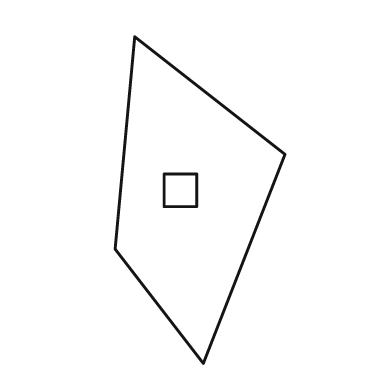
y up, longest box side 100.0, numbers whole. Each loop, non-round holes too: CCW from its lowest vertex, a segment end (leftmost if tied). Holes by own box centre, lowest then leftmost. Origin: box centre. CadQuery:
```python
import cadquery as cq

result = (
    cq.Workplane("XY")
    .moveTo(1.0, -50.0)
    .lineTo(26.0, 14.0)
    .lineTo(-20.0, 50.0)
    .lineTo(-26.0, -15.0)
    .close()
    .moveTo(-11.0, -2.0)
    .lineTo(-1.0, -2.0)
    .lineTo(-1.0, 8.0)
    .lineTo(-11.0, 8.0)
    .close()
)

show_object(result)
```